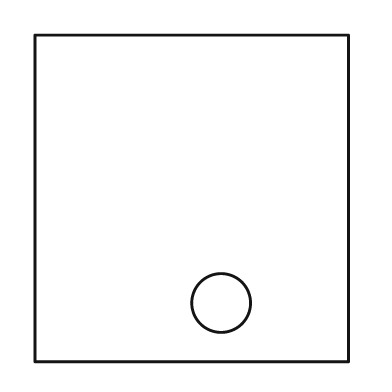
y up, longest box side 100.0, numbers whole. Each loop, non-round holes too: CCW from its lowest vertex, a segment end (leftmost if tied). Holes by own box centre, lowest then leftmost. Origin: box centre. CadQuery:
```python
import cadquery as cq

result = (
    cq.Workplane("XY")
    .moveTo(-48.0, -50.0)
    .lineTo(48.0, -50.0)
    .lineTo(48.0, 50.0)
    .lineTo(-48.0, 50.0)
    .close()
    .moveTo(9.0, -32.0)
    .circle(9.0)
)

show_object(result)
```